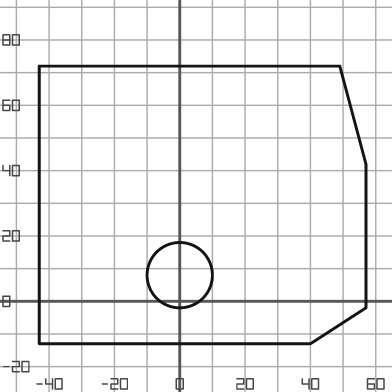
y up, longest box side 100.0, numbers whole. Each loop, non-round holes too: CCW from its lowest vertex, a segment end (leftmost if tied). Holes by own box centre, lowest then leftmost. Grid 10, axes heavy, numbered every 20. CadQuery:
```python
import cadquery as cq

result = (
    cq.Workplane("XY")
    .moveTo(-43.0, -13.0)
    .lineTo(40.0, -13.0)
    .lineTo(57.0, -2.0)
    .lineTo(57.0, 42.0)
    .lineTo(49.0, 72.0)
    .lineTo(-43.0, 72.0)
    .close()
    .moveTo(0.0, 8.0)
    .circle(10.0)
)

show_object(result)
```